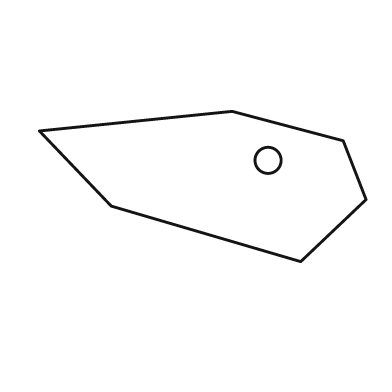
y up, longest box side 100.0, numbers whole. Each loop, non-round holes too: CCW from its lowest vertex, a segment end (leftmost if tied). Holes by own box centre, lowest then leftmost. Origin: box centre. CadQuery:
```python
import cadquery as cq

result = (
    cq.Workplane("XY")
    .moveTo(30.0, -23.0)
    .lineTo(50.0, -4.0)
    .lineTo(43.0, 14.0)
    .lineTo(9.0, 23.0)
    .lineTo(-50.0, 17.0)
    .lineTo(-28.0, -6.0)
    .close()
    .moveTo(20.0, 8.0)
    .circle(4.0)
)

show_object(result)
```